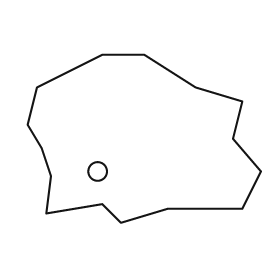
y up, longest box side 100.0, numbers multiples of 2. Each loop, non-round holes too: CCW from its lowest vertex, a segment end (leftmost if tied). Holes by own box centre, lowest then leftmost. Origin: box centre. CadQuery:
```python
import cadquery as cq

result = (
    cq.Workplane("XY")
    .moveTo(-10.0, -36.0)
    .lineTo(10.0, -30.0)
    .lineTo(42.0, -30.0)
    .lineTo(50.0, -14.0)
    .lineTo(38.0, 0.0)
    .lineTo(42.0, 16.0)
    .lineTo(22.0, 22.0)
    .lineTo(0.0, 36.0)
    .lineTo(-18.0, 36.0)
    .lineTo(-46.0, 22.0)
    .lineTo(-50.0, 6.0)
    .lineTo(-44.0, -4.0)
    .lineTo(-40.0, -16.0)
    .lineTo(-42.0, -32.0)
    .lineTo(-18.0, -28.0)
    .close()
    .moveTo(-20.0, -14.0)
    .circle(4.0)
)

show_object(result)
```